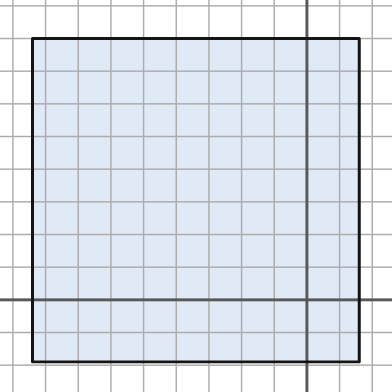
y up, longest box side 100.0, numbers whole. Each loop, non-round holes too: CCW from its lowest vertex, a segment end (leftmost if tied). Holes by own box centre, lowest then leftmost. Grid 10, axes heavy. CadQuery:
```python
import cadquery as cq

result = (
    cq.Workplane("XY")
    .moveTo(-84.0, -19.0)
    .lineTo(16.0, -19.0)
    .lineTo(16.0, 80.0)
    .lineTo(-84.0, 80.0)
    .close()
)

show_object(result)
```